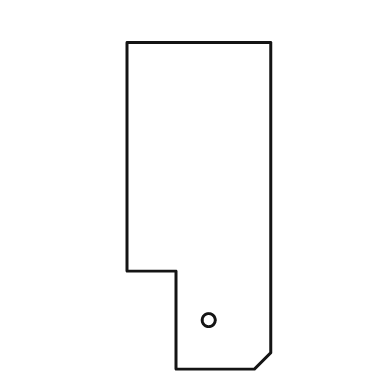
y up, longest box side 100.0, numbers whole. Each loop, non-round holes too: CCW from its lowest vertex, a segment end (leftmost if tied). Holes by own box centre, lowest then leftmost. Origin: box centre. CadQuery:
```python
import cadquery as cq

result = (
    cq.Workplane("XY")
    .moveTo(-7.0, -50.0)
    .lineTo(17.0, -50.0)
    .lineTo(22.0, -45.0)
    .lineTo(22.0, 50.0)
    .lineTo(-22.0, 50.0)
    .lineTo(-22.0, -20.0)
    .lineTo(-7.0, -20.0)
    .close()
    .moveTo(3.0, -35.0)
    .circle(2.0)
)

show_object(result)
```